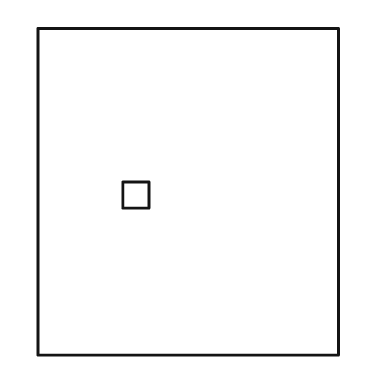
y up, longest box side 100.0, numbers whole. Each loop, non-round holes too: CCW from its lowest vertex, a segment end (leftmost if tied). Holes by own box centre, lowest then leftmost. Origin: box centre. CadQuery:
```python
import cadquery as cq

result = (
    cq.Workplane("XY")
    .moveTo(-46.0, -50.0)
    .lineTo(46.0, -50.0)
    .lineTo(46.0, 50.0)
    .lineTo(-46.0, 50.0)
    .close()
    .moveTo(-20.0, -5.0)
    .lineTo(-12.0, -5.0)
    .lineTo(-12.0, 3.0)
    .lineTo(-20.0, 3.0)
    .close()
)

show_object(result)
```